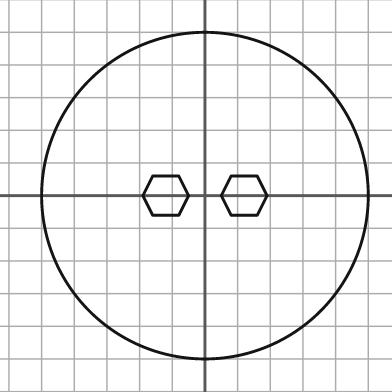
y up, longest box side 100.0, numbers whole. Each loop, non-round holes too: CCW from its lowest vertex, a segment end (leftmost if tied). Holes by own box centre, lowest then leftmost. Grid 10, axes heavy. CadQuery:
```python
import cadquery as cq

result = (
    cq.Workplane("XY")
    .moveTo(0.0, 0.0)
    .circle(50.0)
    .moveTo(-16.0, -6.0)
    .lineTo(-8.0, -6.0)
    .lineTo(-5.0, 0.0)
    .lineTo(-8.0, 6.0)
    .lineTo(-16.0, 6.0)
    .lineTo(-19.0, 0.0)
    .close()
    .moveTo(8.0, -6.0)
    .lineTo(16.0, -6.0)
    .lineTo(19.0, 0.0)
    .lineTo(16.0, 6.0)
    .lineTo(8.0, 6.0)
    .lineTo(5.0, 0.0)
    .close()
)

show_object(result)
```